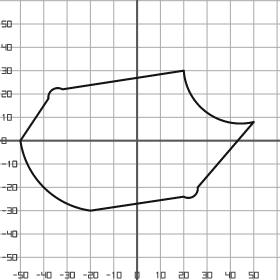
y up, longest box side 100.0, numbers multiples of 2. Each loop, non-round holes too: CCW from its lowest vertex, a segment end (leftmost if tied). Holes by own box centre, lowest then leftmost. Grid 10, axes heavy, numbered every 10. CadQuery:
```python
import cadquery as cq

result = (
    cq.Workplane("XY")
    .moveTo(-20.0, -30.0)
    .lineTo(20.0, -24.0)
    .threePointArc((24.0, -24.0), (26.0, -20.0))
    .lineTo(50.0, 8.0)
    .threePointArc((30.0, 12.0), (20.0, 30.0))
    .lineTo(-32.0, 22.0)
    .threePointArc((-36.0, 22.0), (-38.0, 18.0))
    .lineTo(-50.0, 0.0)
    .threePointArc((-40.0, -20.0), (-20.0, -30.0))
    .close()
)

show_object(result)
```